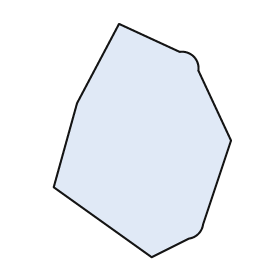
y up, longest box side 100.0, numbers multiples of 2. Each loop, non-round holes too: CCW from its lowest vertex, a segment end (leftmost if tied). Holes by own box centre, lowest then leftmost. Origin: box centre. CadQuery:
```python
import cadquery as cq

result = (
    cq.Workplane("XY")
    .moveTo(4.0, -50.0)
    .lineTo(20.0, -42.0)
    .threePointArc((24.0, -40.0), (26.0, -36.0))
    .lineTo(38.0, 0.0)
    .lineTo(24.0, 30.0)
    .threePointArc((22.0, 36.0), (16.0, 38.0))
    .lineTo(-10.0, 50.0)
    .lineTo(-28.0, 16.0)
    .lineTo(-38.0, -20.0)
    .close()
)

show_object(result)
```